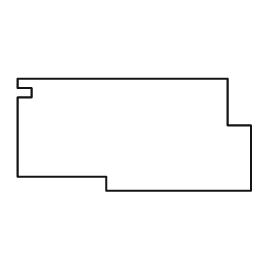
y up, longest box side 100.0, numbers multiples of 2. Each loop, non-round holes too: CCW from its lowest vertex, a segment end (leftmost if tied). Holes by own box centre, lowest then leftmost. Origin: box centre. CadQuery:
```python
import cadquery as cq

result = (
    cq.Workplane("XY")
    .moveTo(-12.0, -24.0)
    .lineTo(50.0, -24.0)
    .lineTo(50.0, 4.0)
    .lineTo(40.0, 4.0)
    .lineTo(40.0, 24.0)
    .lineTo(-50.0, 24.0)
    .lineTo(-50.0, 20.0)
    .lineTo(-44.0, 20.0)
    .lineTo(-44.0, 16.0)
    .lineTo(-50.0, 16.0)
    .lineTo(-50.0, -18.0)
    .lineTo(-12.0, -18.0)
    .close()
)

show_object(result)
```